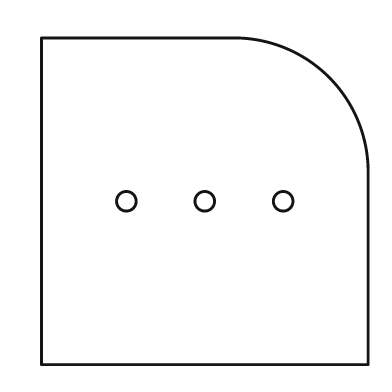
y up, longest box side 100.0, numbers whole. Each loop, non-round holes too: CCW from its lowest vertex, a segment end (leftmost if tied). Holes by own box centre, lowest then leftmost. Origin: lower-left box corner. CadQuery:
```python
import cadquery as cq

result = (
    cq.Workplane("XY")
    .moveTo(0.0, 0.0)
    .lineTo(100.0, 0.0)
    .lineTo(100.0, 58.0)
    .threePointArc((88.0, 88.0), (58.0, 100.0))
    .lineTo(0.0, 100.0)
    .close()
    .moveTo(26.0, 50.0)
    .circle(3.0)
    .moveTo(50.0, 50.0)
    .circle(3.0)
    .moveTo(74.0, 50.0)
    .circle(3.0)
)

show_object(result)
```